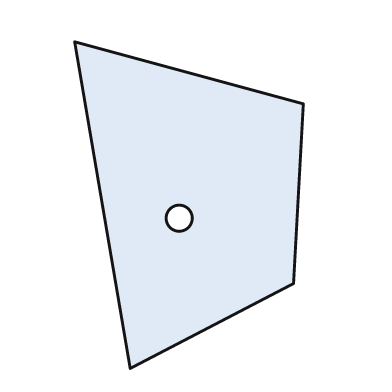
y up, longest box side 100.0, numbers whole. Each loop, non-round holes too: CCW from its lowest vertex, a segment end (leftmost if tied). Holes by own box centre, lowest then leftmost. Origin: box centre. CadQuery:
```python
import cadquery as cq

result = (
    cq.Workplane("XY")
    .moveTo(-18.0, -50.0)
    .lineTo(32.0, -24.0)
    .lineTo(35.0, 31.0)
    .lineTo(-35.0, 50.0)
    .close()
    .moveTo(-3.0, -4.0)
    .circle(4.0)
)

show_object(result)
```